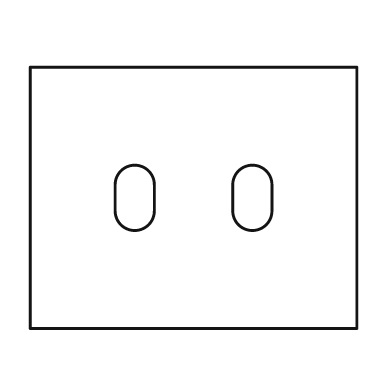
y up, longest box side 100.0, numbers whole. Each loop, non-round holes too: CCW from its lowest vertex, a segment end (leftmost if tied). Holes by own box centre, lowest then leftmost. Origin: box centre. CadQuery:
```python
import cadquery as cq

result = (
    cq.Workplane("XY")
    .moveTo(-50.0, -40.0)
    .lineTo(50.0, -40.0)
    .lineTo(50.0, 40.0)
    .lineTo(-50.0, 40.0)
    .close()
    .moveTo(-24.0, -4.0)
    .threePointArc((-18.0, -10.0), (-12.0, -4.0))
    .lineTo(-12.0, 4.0)
    .threePointArc((-18.0, 10.0), (-24.0, 4.0))
    .close()
    .moveTo(12.0, -4.0)
    .threePointArc((18.0, -10.0), (24.0, -4.0))
    .lineTo(24.0, 4.0)
    .threePointArc((18.0, 10.0), (12.0, 4.0))
    .close()
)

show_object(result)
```